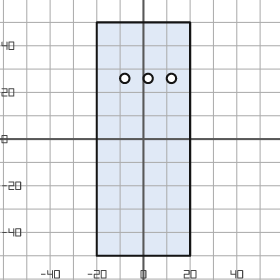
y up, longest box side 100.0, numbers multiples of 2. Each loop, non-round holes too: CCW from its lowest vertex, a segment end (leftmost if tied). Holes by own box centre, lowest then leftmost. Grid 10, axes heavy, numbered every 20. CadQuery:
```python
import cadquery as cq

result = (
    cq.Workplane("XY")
    .moveTo(-20.0, -50.0)
    .lineTo(20.0, -50.0)
    .lineTo(20.0, 50.0)
    .lineTo(-20.0, 50.0)
    .close()
    .moveTo(-8.0, 26.0)
    .circle(2.0)
    .moveTo(2.0, 26.0)
    .circle(2.0)
    .moveTo(12.0, 26.0)
    .circle(2.0)
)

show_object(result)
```